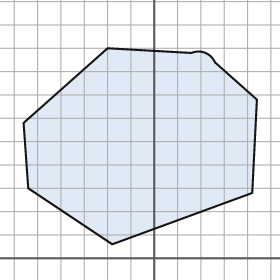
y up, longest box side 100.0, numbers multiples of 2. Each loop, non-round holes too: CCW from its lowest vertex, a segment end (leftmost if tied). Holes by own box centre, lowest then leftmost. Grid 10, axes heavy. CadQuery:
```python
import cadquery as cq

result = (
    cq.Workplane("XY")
    .moveTo(-18.0, 6.0)
    .lineTo(42.0, 28.0)
    .lineTo(44.0, 68.0)
    .lineTo(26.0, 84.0)
    .threePointArc((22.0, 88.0), (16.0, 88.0))
    .lineTo(-20.0, 90.0)
    .lineTo(-56.0, 58.0)
    .lineTo(-54.0, 30.0)
    .close()
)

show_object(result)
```